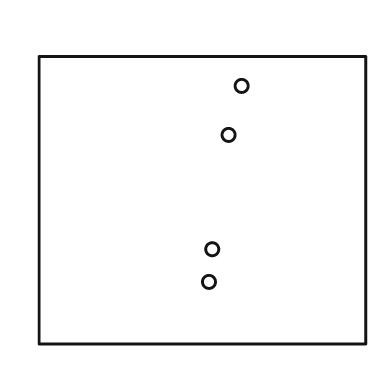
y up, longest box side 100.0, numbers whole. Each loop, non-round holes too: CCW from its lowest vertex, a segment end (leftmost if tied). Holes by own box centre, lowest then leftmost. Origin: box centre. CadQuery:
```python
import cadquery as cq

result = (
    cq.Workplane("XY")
    .moveTo(-50.0, -44.0)
    .lineTo(50.0, -44.0)
    .lineTo(50.0, 44.0)
    .lineTo(-50.0, 44.0)
    .close()
    .moveTo(2.0, -25.0)
    .circle(2.0)
    .moveTo(3.0, -15.0)
    .circle(2.0)
    .moveTo(8.0, 20.0)
    .circle(2.0)
    .moveTo(12.0, 35.0)
    .circle(2.0)
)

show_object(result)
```